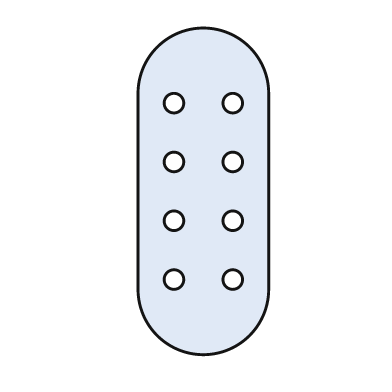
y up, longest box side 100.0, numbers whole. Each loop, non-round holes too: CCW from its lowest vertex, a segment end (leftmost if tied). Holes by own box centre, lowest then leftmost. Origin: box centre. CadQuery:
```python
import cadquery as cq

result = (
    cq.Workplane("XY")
    .moveTo(-20.0, -30.0)
    .threePointArc((0.0, -50.0), (20.0, -30.0))
    .lineTo(20.0, 30.0)
    .threePointArc((0.0, 50.0), (-20.0, 30.0))
    .close()
    .moveTo(-9.0, -27.0)
    .circle(3.0)
    .moveTo(9.0, -27.0)
    .circle(3.0)
    .moveTo(-9.0, -9.0)
    .circle(3.0)
    .moveTo(9.0, -9.0)
    .circle(3.0)
    .moveTo(-9.0, 9.0)
    .circle(3.0)
    .moveTo(9.0, 9.0)
    .circle(3.0)
    .moveTo(-9.0, 27.0)
    .circle(3.0)
    .moveTo(9.0, 27.0)
    .circle(3.0)
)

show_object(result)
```